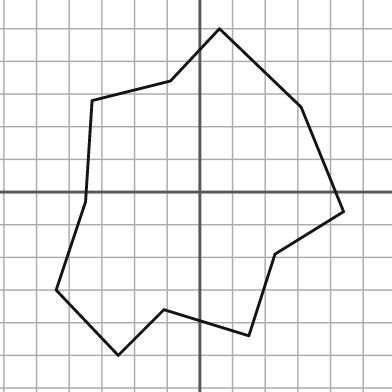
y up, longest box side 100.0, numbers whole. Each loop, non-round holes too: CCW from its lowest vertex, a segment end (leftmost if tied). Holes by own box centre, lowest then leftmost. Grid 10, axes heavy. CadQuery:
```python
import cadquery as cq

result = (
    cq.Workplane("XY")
    .moveTo(-25.0, -50.0)
    .lineTo(-11.0, -36.0)
    .lineTo(15.0, -44.0)
    .lineTo(23.0, -19.0)
    .lineTo(44.0, -6.0)
    .lineTo(31.0, 26.0)
    .lineTo(6.0, 50.0)
    .lineTo(-9.0, 34.0)
    .lineTo(-33.0, 28.0)
    .lineTo(-35.0, -3.0)
    .lineTo(-44.0, -30.0)
    .close()
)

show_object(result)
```